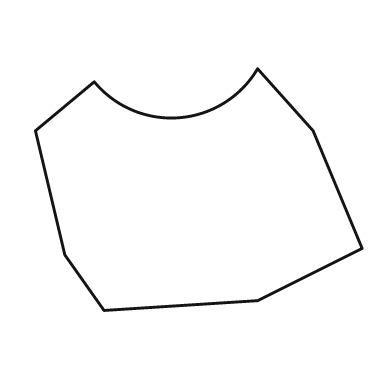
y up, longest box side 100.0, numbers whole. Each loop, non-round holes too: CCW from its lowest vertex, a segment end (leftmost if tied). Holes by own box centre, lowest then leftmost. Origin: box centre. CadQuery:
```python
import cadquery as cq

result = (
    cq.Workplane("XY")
    .moveTo(-29.0, -37.0)
    .lineTo(18.0, -34.0)
    .lineTo(50.0, -18.0)
    .lineTo(35.0, 18.0)
    .lineTo(18.0, 37.0)
    .threePointArc((-6.0, 22.0), (-32.0, 33.0))
    .lineTo(-50.0, 18.0)
    .lineTo(-41.0, -20.0)
    .close()
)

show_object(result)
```